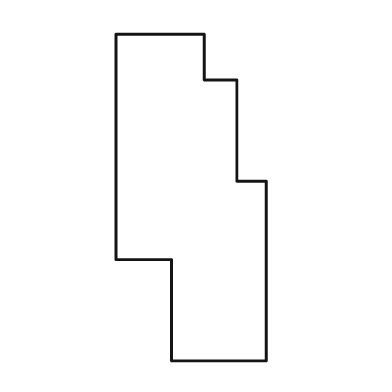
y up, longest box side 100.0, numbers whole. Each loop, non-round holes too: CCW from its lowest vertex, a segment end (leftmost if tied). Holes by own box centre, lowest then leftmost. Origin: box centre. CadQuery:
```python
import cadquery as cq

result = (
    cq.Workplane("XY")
    .moveTo(-6.0, -50.0)
    .lineTo(23.0, -50.0)
    .lineTo(23.0, 5.0)
    .lineTo(14.0, 5.0)
    .lineTo(14.0, 36.0)
    .lineTo(4.0, 36.0)
    .lineTo(4.0, 50.0)
    .lineTo(-23.0, 50.0)
    .lineTo(-23.0, -19.0)
    .lineTo(-6.0, -19.0)
    .close()
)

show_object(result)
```